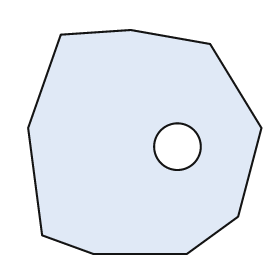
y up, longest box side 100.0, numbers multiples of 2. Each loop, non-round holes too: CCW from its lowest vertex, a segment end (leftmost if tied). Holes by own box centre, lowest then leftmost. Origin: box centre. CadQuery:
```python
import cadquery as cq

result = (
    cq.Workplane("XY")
    .moveTo(-22.0, -48.0)
    .lineTo(18.0, -48.0)
    .lineTo(40.0, -32.0)
    .lineTo(50.0, 6.0)
    .lineTo(28.0, 42.0)
    .lineTo(-6.0, 48.0)
    .lineTo(-36.0, 46.0)
    .lineTo(-50.0, 6.0)
    .lineTo(-44.0, -40.0)
    .close()
    .moveTo(14.0, -2.0)
    .circle(10.0)
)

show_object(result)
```